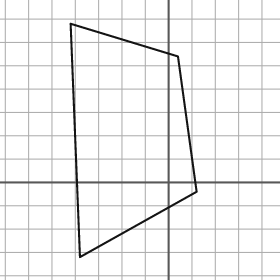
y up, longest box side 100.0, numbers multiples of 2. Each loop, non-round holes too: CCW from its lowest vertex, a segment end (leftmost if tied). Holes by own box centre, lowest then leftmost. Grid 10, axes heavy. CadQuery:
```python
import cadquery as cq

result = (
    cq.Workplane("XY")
    .moveTo(-38.0, -32.0)
    .lineTo(12.0, -4.0)
    .lineTo(4.0, 54.0)
    .lineTo(-42.0, 68.0)
    .close()
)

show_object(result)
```